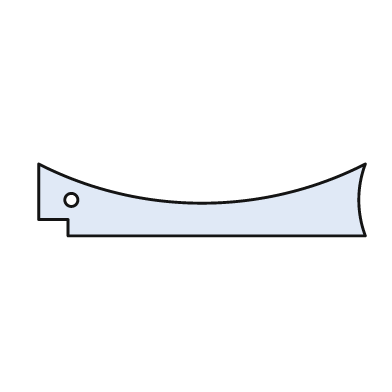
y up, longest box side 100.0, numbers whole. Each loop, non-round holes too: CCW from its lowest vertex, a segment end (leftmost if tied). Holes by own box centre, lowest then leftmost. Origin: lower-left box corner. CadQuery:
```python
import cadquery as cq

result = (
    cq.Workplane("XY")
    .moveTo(9.0, 0.0)
    .lineTo(100.0, 0.0)
    .threePointArc((98.0, 11.0), (100.0, 22.0))
    .threePointArc((50.0, 10.0), (0.0, 22.0))
    .lineTo(0.0, 5.0)
    .lineTo(9.0, 5.0)
    .close()
    .moveTo(10.0, 11.0)
    .circle(2.0)
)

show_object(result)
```